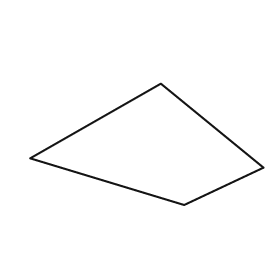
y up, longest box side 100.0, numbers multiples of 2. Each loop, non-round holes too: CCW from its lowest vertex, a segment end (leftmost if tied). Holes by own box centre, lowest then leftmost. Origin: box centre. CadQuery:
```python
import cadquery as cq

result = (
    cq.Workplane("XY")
    .moveTo(16.0, -26.0)
    .lineTo(50.0, -10.0)
    .lineTo(6.0, 26.0)
    .lineTo(-50.0, -6.0)
    .close()
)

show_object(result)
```